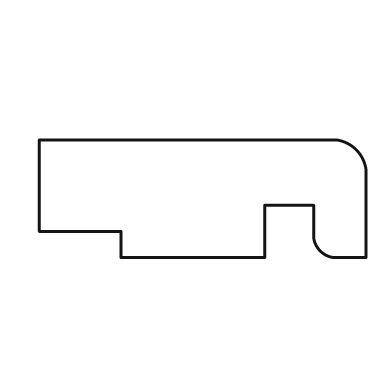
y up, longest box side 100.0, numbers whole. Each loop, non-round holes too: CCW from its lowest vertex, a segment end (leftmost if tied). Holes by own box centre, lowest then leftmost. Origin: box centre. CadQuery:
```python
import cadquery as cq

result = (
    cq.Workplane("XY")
    .moveTo(-25.0, -18.0)
    .lineTo(19.0, -18.0)
    .lineTo(19.0, -2.0)
    .lineTo(34.0, -2.0)
    .lineTo(34.0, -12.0)
    .threePointArc((36.0, -16.0), (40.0, -18.0))
    .lineTo(50.0, -18.0)
    .lineTo(50.0, 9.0)
    .threePointArc((47.0, 15.0), (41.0, 18.0))
    .lineTo(-50.0, 18.0)
    .lineTo(-50.0, -10.0)
    .lineTo(-25.0, -10.0)
    .close()
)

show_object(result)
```